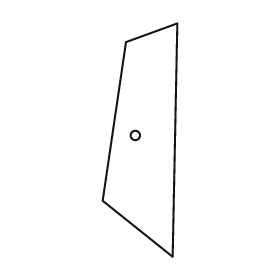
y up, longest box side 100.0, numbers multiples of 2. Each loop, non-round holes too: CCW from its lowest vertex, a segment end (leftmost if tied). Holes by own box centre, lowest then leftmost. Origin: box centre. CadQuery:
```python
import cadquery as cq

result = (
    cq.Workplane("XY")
    .moveTo(14.0, -50.0)
    .lineTo(16.0, 50.0)
    .lineTo(-6.0, 42.0)
    .lineTo(-16.0, -26.0)
    .close()
    .moveTo(-2.0, 2.0)
    .circle(2.0)
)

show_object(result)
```